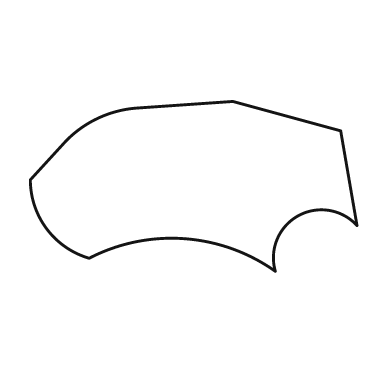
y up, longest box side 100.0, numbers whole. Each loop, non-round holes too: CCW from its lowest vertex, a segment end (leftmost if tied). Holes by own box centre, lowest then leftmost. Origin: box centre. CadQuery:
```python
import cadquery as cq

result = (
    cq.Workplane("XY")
    .moveTo(25.0, -26.0)
    .threePointArc((32.0, -9.0), (50.0, -12.0))
    .lineTo(45.0, 17.0)
    .lineTo(12.0, 26.0)
    .lineTo(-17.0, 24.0)
    .threePointArc((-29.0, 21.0), (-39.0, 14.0))
    .lineTo(-50.0, 2.0)
    .threePointArc((-45.0, -13.0), (-32.0, -22.0))
    .threePointArc((-3.0, -16.0), (25.0, -26.0))
    .close()
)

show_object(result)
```